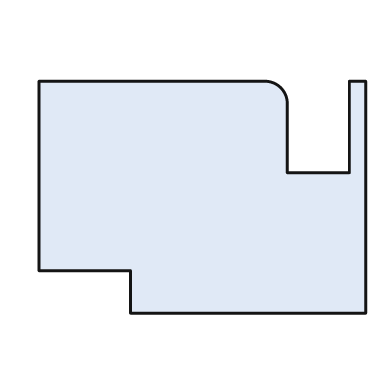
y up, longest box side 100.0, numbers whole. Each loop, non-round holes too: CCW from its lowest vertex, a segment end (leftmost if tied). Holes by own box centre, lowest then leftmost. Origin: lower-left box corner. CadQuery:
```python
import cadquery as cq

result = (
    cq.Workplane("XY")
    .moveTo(28.0, 0.0)
    .lineTo(100.0, 0.0)
    .lineTo(100.0, 71.0)
    .lineTo(95.0, 71.0)
    .lineTo(95.0, 43.0)
    .lineTo(76.0, 43.0)
    .lineTo(76.0, 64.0)
    .threePointArc((74.0, 69.0), (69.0, 71.0))
    .lineTo(0.0, 71.0)
    .lineTo(0.0, 13.0)
    .lineTo(28.0, 13.0)
    .close()
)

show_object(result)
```